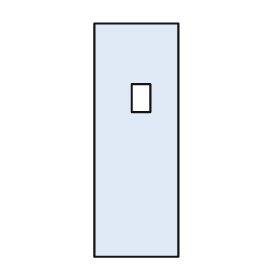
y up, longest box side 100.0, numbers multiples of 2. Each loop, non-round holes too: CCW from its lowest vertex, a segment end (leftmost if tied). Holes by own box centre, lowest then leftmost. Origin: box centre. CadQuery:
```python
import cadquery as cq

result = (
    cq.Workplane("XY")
    .moveTo(-18.0, -50.0)
    .lineTo(18.0, -50.0)
    .lineTo(18.0, 50.0)
    .lineTo(-18.0, 50.0)
    .close()
    .moveTo(-2.0, 12.0)
    .lineTo(6.0, 12.0)
    .lineTo(6.0, 24.0)
    .lineTo(-2.0, 24.0)
    .close()
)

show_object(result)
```